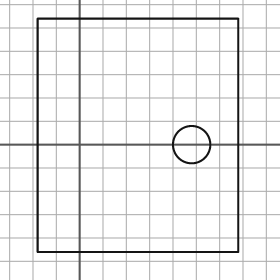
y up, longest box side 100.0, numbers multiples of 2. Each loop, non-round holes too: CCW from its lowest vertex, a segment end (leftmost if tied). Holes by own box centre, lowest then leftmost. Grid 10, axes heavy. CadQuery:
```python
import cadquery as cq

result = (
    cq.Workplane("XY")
    .moveTo(-18.0, -46.0)
    .lineTo(68.0, -46.0)
    .lineTo(68.0, 54.0)
    .lineTo(-18.0, 54.0)
    .close()
    .moveTo(48.0, 0.0)
    .circle(8.0)
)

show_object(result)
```